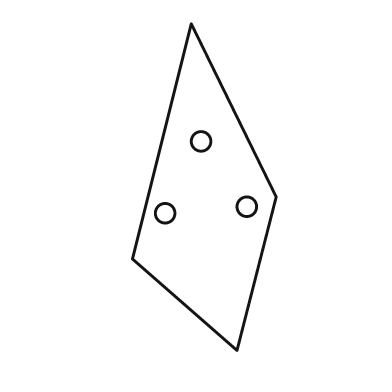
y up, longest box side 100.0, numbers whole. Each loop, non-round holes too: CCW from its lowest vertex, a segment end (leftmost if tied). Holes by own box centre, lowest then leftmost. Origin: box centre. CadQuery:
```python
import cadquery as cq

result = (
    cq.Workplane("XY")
    .moveTo(10.0, -50.0)
    .lineTo(22.0, -3.0)
    .lineTo(-4.0, 50.0)
    .lineTo(-22.0, -22.0)
    .close()
    .moveTo(-12.0, -8.0)
    .circle(3.0)
    .moveTo(13.0, -6.0)
    .circle(3.0)
    .moveTo(-1.0, 14.0)
    .circle(3.0)
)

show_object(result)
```